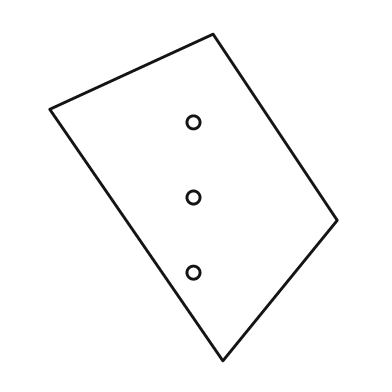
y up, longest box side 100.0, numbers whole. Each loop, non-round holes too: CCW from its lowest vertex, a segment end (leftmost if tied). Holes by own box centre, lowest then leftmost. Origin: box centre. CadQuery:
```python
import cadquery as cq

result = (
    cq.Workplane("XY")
    .moveTo(9.0, -50.0)
    .lineTo(44.0, -7.0)
    .lineTo(6.0, 50.0)
    .lineTo(-44.0, 27.0)
    .close()
    .moveTo(0.0, -23.0)
    .circle(2.0)
    .moveTo(0.0, 0.0)
    .circle(2.0)
    .moveTo(0.0, 23.0)
    .circle(2.0)
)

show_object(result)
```